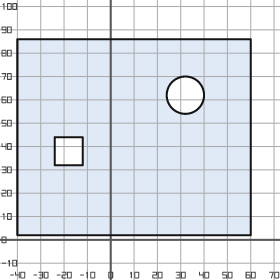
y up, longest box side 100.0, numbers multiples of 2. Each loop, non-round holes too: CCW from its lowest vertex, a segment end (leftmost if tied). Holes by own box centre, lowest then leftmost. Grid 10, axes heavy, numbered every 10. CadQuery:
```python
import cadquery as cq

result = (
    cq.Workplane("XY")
    .moveTo(-40.0, 2.0)
    .lineTo(60.0, 2.0)
    .lineTo(60.0, 86.0)
    .lineTo(-40.0, 86.0)
    .close()
    .moveTo(-24.0, 32.0)
    .lineTo(-12.0, 32.0)
    .lineTo(-12.0, 44.0)
    .lineTo(-24.0, 44.0)
    .close()
    .moveTo(32.0, 62.0)
    .circle(8.0)
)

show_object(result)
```